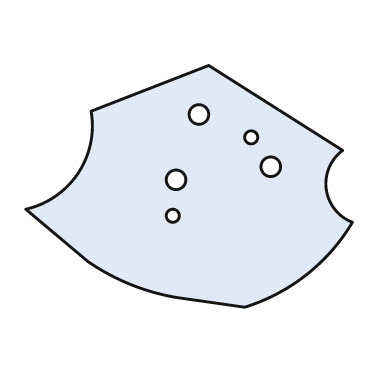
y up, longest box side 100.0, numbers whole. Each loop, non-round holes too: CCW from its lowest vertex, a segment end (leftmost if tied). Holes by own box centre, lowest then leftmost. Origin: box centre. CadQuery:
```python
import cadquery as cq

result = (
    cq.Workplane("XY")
    .moveTo(17.0, -37.0)
    .threePointArc((36.0, -27.0), (50.0, -11.0))
    .threePointArc((42.0, -1.0), (47.0, 11.0))
    .lineTo(6.0, 37.0)
    .lineTo(-30.0, 23.0)
    .threePointArc((-34.0, 4.0), (-50.0, -7.0))
    .lineTo(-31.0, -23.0)
    .threePointArc((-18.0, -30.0), (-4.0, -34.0))
    .close()
    .moveTo(-5.0, -9.0)
    .circle(2.0)
    .moveTo(-4.0, 2.0)
    .circle(3.0)
    .moveTo(25.0, 6.0)
    .circle(3.0)
    .moveTo(19.0, 15.0)
    .circle(2.0)
    .moveTo(3.0, 22.0)
    .circle(3.0)
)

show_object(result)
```